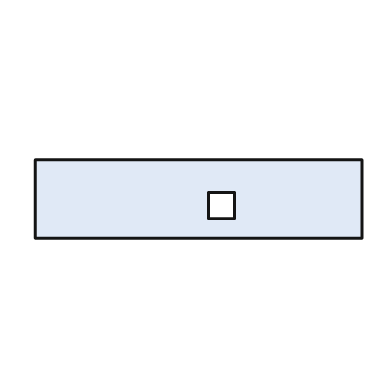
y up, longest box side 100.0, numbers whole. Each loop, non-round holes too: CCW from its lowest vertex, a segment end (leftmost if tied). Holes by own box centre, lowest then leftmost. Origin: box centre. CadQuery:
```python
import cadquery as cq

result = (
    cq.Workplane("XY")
    .moveTo(-50.0, -12.0)
    .lineTo(50.0, -12.0)
    .lineTo(50.0, 12.0)
    .lineTo(-50.0, 12.0)
    .close()
    .moveTo(3.0, -6.0)
    .lineTo(11.0, -6.0)
    .lineTo(11.0, 2.0)
    .lineTo(3.0, 2.0)
    .close()
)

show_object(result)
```